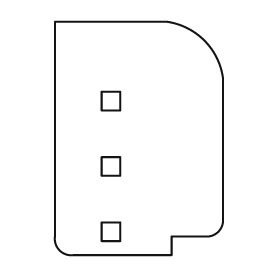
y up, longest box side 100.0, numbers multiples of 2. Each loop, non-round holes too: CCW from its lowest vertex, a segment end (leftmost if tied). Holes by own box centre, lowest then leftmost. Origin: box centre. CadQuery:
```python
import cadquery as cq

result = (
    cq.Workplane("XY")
    .moveTo(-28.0, -50.0)
    .lineTo(14.0, -50.0)
    .lineTo(14.0, -42.0)
    .lineTo(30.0, -42.0)
    .threePointArc((34.0, -40.0), (36.0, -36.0))
    .lineTo(36.0, 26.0)
    .threePointArc((28.0, 42.0), (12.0, 50.0))
    .lineTo(-36.0, 50.0)
    .lineTo(-36.0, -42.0)
    .threePointArc((-34.0, -48.0), (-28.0, -50.0))
    .close()
    .moveTo(-16.0, -44.0)
    .lineTo(-8.0, -44.0)
    .lineTo(-8.0, -36.0)
    .lineTo(-16.0, -36.0)
    .close()
    .moveTo(-16.0, -16.0)
    .lineTo(-8.0, -16.0)
    .lineTo(-8.0, -8.0)
    .lineTo(-16.0, -8.0)
    .close()
    .moveTo(-16.0, 12.0)
    .lineTo(-8.0, 12.0)
    .lineTo(-8.0, 20.0)
    .lineTo(-16.0, 20.0)
    .close()
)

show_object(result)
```